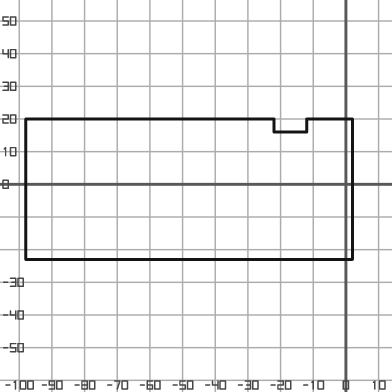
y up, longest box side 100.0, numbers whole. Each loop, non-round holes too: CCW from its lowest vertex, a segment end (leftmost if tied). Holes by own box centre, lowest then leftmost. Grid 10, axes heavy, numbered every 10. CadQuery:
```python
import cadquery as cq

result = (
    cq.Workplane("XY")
    .moveTo(-98.0, -23.0)
    .lineTo(2.0, -23.0)
    .lineTo(2.0, 20.0)
    .lineTo(-12.0, 20.0)
    .lineTo(-12.0, 16.0)
    .lineTo(-22.0, 16.0)
    .lineTo(-22.0, 20.0)
    .lineTo(-98.0, 20.0)
    .close()
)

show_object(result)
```